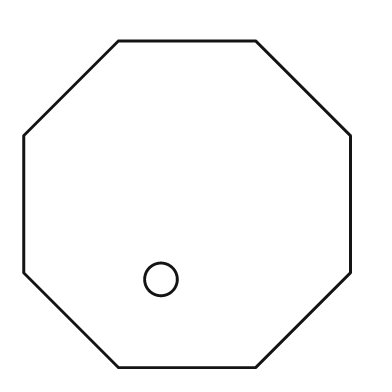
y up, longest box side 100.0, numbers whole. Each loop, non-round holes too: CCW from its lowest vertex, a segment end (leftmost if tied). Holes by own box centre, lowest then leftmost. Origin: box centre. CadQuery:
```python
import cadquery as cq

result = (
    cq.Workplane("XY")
    .moveTo(-21.0, -50.0)
    .lineTo(21.0, -50.0)
    .lineTo(50.0, -21.0)
    .lineTo(50.0, 21.0)
    .lineTo(21.0, 50.0)
    .lineTo(-21.0, 50.0)
    .lineTo(-50.0, 21.0)
    .lineTo(-50.0, -21.0)
    .close()
    .moveTo(-8.0, -23.0)
    .circle(5.0)
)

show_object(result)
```